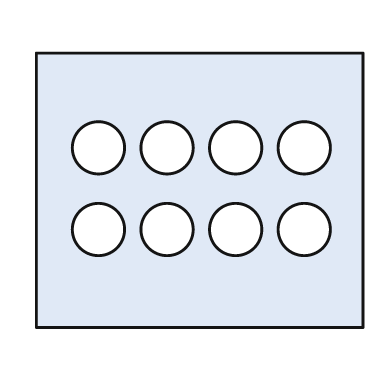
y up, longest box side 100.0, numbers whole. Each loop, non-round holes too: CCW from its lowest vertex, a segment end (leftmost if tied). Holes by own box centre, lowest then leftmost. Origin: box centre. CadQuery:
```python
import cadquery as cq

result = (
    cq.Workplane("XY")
    .moveTo(-50.0, -42.0)
    .lineTo(50.0, -42.0)
    .lineTo(50.0, 42.0)
    .lineTo(-50.0, 42.0)
    .close()
    .moveTo(-31.0, -12.0)
    .circle(8.0)
    .moveTo(-10.0, -12.0)
    .circle(8.0)
    .moveTo(11.0, -12.0)
    .circle(8.0)
    .moveTo(32.0, -12.0)
    .circle(8.0)
    .moveTo(-31.0, 13.0)
    .circle(8.0)
    .moveTo(-10.0, 13.0)
    .circle(8.0)
    .moveTo(11.0, 13.0)
    .circle(8.0)
    .moveTo(32.0, 13.0)
    .circle(8.0)
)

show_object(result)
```